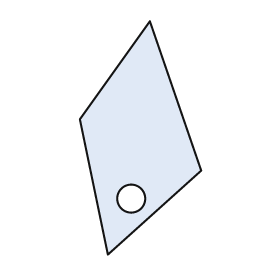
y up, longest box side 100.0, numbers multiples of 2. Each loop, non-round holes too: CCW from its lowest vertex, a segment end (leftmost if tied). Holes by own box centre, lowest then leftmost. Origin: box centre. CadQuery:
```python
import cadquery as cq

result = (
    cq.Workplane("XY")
    .moveTo(-14.0, -50.0)
    .lineTo(26.0, -14.0)
    .lineTo(4.0, 50.0)
    .lineTo(-26.0, 8.0)
    .close()
    .moveTo(-4.0, -26.0)
    .circle(6.0)
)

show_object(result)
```